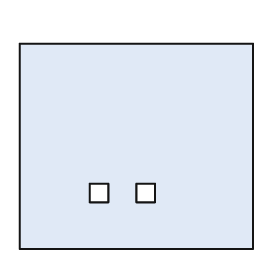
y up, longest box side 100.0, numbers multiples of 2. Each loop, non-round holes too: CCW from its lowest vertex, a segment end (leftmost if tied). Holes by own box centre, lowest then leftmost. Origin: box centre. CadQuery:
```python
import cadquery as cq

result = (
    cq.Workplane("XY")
    .moveTo(-50.0, -44.0)
    .lineTo(50.0, -44.0)
    .lineTo(50.0, 44.0)
    .lineTo(-50.0, 44.0)
    .close()
    .moveTo(-20.0, -24.0)
    .lineTo(-12.0, -24.0)
    .lineTo(-12.0, -16.0)
    .lineTo(-20.0, -16.0)
    .close()
    .moveTo(0.0, -24.0)
    .lineTo(8.0, -24.0)
    .lineTo(8.0, -16.0)
    .lineTo(0.0, -16.0)
    .close()
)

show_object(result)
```